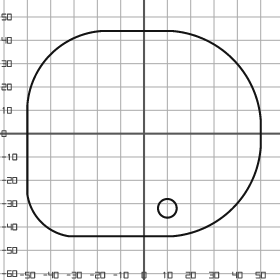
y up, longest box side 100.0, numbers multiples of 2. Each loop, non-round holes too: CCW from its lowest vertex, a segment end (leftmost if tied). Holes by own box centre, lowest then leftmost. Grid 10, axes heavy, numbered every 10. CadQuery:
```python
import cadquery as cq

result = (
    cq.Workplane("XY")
    .moveTo(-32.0, -44.0)
    .lineTo(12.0, -44.0)
    .threePointArc((38.0, -32.0), (50.0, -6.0))
    .lineTo(50.0, 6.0)
    .threePointArc((38.0, 32.0), (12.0, 44.0))
    .lineTo(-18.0, 44.0)
    .threePointArc((-40.0, 34.0), (-50.0, 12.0))
    .lineTo(-50.0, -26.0)
    .threePointArc((-44.0, -38.0), (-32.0, -44.0))
    .close()
    .moveTo(10.0, -32.0)
    .circle(4.0)
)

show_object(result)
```